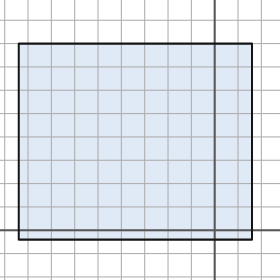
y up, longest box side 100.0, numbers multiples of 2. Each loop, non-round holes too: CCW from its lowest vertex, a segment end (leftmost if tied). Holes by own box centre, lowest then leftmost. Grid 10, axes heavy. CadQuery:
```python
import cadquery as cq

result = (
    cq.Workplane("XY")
    .moveTo(-84.0, -4.0)
    .lineTo(16.0, -4.0)
    .lineTo(16.0, 80.0)
    .lineTo(-84.0, 80.0)
    .close()
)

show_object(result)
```